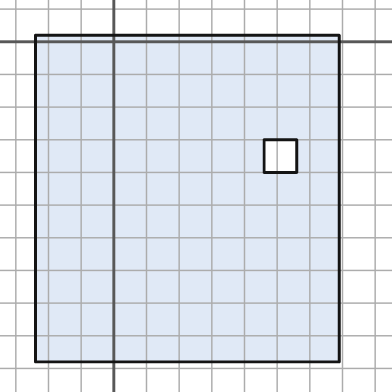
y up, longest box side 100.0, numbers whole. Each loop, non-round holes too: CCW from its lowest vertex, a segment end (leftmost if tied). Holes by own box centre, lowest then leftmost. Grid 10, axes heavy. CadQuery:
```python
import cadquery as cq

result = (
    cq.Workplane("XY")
    .moveTo(-24.0, -98.0)
    .lineTo(69.0, -98.0)
    .lineTo(69.0, 2.0)
    .lineTo(-24.0, 2.0)
    .close()
    .moveTo(46.0, -40.0)
    .lineTo(56.0, -40.0)
    .lineTo(56.0, -30.0)
    .lineTo(46.0, -30.0)
    .close()
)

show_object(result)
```